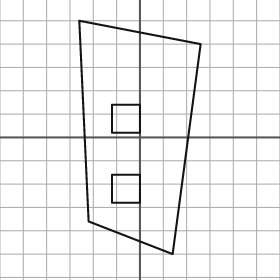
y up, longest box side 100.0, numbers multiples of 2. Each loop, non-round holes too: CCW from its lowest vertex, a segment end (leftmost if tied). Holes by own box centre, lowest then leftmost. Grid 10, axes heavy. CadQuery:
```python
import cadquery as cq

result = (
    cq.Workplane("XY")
    .moveTo(14.0, -50.0)
    .lineTo(26.0, 40.0)
    .lineTo(-26.0, 50.0)
    .lineTo(-22.0, -36.0)
    .close()
    .moveTo(-12.0, -28.0)
    .lineTo(0.0, -28.0)
    .lineTo(0.0, -16.0)
    .lineTo(-12.0, -16.0)
    .close()
    .moveTo(-12.0, 2.0)
    .lineTo(0.0, 2.0)
    .lineTo(0.0, 14.0)
    .lineTo(-12.0, 14.0)
    .close()
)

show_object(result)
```